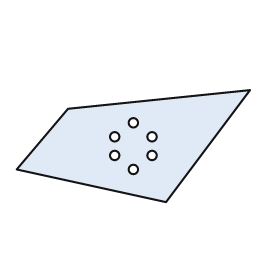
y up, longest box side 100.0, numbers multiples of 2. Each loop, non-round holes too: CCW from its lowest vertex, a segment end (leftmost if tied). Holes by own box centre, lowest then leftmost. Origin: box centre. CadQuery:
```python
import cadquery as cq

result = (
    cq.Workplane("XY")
    .moveTo(14.0, -24.0)
    .lineTo(50.0, 24.0)
    .lineTo(-28.0, 16.0)
    .lineTo(-50.0, -10.0)
    .close()
    .moveTo(0.0, -10.0)
    .circle(2.0)
    .moveTo(-8.0, -4.0)
    .circle(2.0)
    .moveTo(8.0, -4.0)
    .circle(2.0)
    .moveTo(-8.0, 4.0)
    .circle(2.0)
    .moveTo(8.0, 4.0)
    .circle(2.0)
    .moveTo(0.0, 10.0)
    .circle(2.0)
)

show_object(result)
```